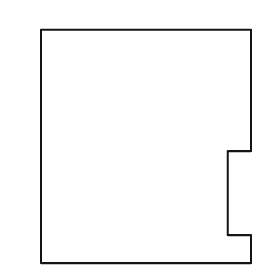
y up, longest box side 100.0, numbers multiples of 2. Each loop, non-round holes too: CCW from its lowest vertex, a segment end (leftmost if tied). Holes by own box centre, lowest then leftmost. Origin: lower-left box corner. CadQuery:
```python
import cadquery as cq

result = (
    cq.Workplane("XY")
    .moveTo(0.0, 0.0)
    .lineTo(90.0, 0.0)
    .lineTo(90.0, 12.0)
    .lineTo(80.0, 12.0)
    .lineTo(80.0, 48.0)
    .lineTo(90.0, 48.0)
    .lineTo(90.0, 100.0)
    .lineTo(0.0, 100.0)
    .close()
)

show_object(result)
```